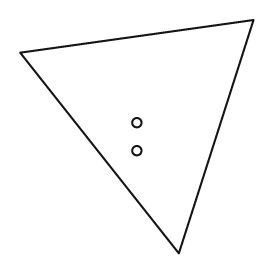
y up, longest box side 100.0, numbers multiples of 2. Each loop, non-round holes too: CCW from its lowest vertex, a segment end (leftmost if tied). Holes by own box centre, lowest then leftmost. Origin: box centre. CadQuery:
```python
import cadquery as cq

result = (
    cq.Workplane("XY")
    .moveTo(18.0, -50.0)
    .lineTo(50.0, 50.0)
    .lineTo(-50.0, 36.0)
    .close()
    .moveTo(0.0, -6.0)
    .circle(2.0)
    .moveTo(0.0, 6.0)
    .circle(2.0)
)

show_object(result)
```